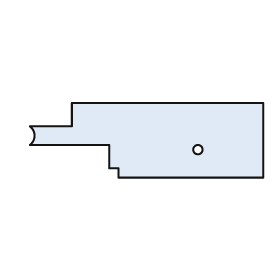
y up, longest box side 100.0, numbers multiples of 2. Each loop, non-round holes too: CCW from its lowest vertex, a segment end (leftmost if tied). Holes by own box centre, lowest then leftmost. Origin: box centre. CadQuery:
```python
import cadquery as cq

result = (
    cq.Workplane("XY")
    .moveTo(-12.0, -16.0)
    .lineTo(50.0, -16.0)
    .lineTo(50.0, 16.0)
    .lineTo(-32.0, 16.0)
    .lineTo(-32.0, 6.0)
    .lineTo(-50.0, 6.0)
    .threePointArc((-48.0, 2.0), (-50.0, -2.0))
    .lineTo(-16.0, -2.0)
    .lineTo(-16.0, -12.0)
    .lineTo(-12.0, -12.0)
    .close()
    .moveTo(22.0, -4.0)
    .circle(2.0)
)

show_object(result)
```